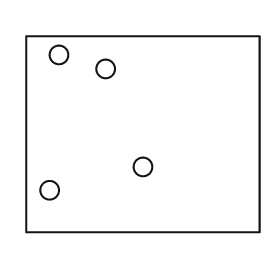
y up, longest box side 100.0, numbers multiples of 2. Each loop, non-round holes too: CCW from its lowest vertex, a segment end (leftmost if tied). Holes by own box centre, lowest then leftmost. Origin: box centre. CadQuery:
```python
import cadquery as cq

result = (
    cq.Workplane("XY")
    .moveTo(-50.0, -42.0)
    .lineTo(50.0, -42.0)
    .lineTo(50.0, 42.0)
    .lineTo(-50.0, 42.0)
    .close()
    .moveTo(-40.0, -24.0)
    .circle(4.0)
    .moveTo(0.0, -14.0)
    .circle(4.0)
    .moveTo(-16.0, 28.0)
    .circle(4.0)
    .moveTo(-36.0, 34.0)
    .circle(4.0)
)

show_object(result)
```